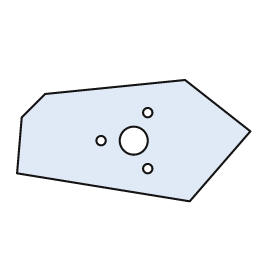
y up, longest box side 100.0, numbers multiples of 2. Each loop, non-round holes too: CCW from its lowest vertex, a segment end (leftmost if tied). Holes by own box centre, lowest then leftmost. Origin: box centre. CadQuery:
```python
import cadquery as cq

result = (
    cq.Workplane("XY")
    .moveTo(24.0, -26.0)
    .lineTo(50.0, 4.0)
    .lineTo(22.0, 26.0)
    .lineTo(-38.0, 20.0)
    .lineTo(-48.0, 10.0)
    .lineTo(-50.0, -14.0)
    .close()
    .moveTo(6.0, -12.0)
    .circle(2.0)
    .moveTo(-14.0, 0.0)
    .circle(2.0)
    .moveTo(0.0, 0.0)
    .circle(6.0)
    .moveTo(6.0, 12.0)
    .circle(2.0)
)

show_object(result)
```